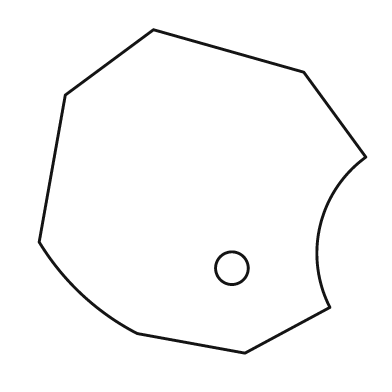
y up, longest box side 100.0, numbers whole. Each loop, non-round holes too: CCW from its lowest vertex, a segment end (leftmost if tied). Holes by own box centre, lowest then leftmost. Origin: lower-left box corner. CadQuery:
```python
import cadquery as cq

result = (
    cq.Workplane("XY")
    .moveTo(63.0, 0.0)
    .lineTo(89.0, 14.0)
    .threePointArc((86.0, 39.0), (100.0, 60.0))
    .lineTo(81.0, 86.0)
    .lineTo(35.0, 99.0)
    .lineTo(8.0, 79.0)
    .lineTo(0.0, 34.0)
    .threePointArc((13.0, 18.0), (30.0, 6.0))
    .close()
    .moveTo(59.0, 26.0)
    .circle(5.0)
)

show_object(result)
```